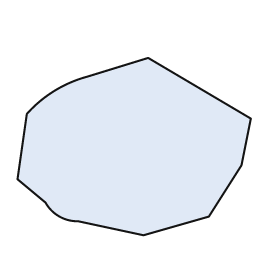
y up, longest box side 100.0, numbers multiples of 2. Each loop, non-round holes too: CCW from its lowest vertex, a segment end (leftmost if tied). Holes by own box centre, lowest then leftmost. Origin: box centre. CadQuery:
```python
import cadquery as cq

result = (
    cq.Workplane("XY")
    .moveTo(4.0, -38.0)
    .lineTo(32.0, -30.0)
    .lineTo(46.0, -8.0)
    .lineTo(50.0, 12.0)
    .lineTo(6.0, 38.0)
    .lineTo(-20.0, 30.0)
    .threePointArc((-34.0, 24.0), (-46.0, 14.0))
    .lineTo(-50.0, -14.0)
    .lineTo(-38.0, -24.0)
    .threePointArc((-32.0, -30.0), (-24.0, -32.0))
    .close()
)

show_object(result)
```